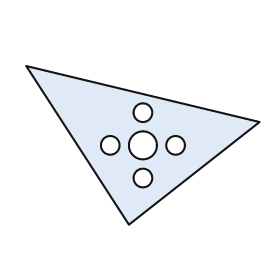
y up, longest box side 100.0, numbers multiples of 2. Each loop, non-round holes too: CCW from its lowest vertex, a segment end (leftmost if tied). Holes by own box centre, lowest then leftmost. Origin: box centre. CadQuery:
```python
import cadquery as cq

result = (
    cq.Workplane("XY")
    .moveTo(-6.0, -34.0)
    .lineTo(50.0, 10.0)
    .lineTo(-50.0, 34.0)
    .close()
    .moveTo(0.0, -14.0)
    .circle(4.0)
    .moveTo(-14.0, 0.0)
    .circle(4.0)
    .moveTo(0.0, 0.0)
    .circle(6.0)
    .moveTo(14.0, 0.0)
    .circle(4.0)
    .moveTo(0.0, 14.0)
    .circle(4.0)
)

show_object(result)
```